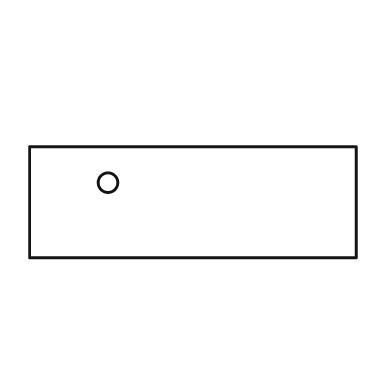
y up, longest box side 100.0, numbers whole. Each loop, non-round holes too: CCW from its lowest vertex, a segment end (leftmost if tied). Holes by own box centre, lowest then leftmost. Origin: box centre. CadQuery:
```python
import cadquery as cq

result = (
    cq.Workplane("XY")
    .moveTo(-50.0, -17.0)
    .lineTo(50.0, -17.0)
    .lineTo(50.0, 17.0)
    .lineTo(-50.0, 17.0)
    .close()
    .moveTo(-26.0, 6.0)
    .circle(3.0)
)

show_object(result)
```